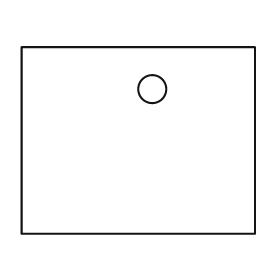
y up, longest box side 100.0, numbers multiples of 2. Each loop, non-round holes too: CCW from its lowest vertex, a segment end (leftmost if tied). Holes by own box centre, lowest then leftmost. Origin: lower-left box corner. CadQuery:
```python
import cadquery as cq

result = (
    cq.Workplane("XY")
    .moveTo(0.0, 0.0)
    .lineTo(100.0, 0.0)
    .lineTo(100.0, 80.0)
    .lineTo(0.0, 80.0)
    .close()
    .moveTo(56.0, 62.0)
    .circle(6.0)
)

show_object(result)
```